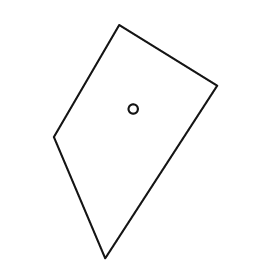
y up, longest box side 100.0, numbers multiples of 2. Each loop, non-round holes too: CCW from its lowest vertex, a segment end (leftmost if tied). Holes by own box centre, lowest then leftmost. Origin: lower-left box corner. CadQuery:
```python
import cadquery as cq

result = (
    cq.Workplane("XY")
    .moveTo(22.0, 0.0)
    .lineTo(70.0, 74.0)
    .lineTo(28.0, 100.0)
    .lineTo(0.0, 52.0)
    .close()
    .moveTo(34.0, 64.0)
    .circle(2.0)
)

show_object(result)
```